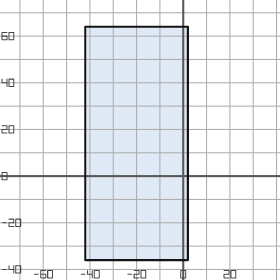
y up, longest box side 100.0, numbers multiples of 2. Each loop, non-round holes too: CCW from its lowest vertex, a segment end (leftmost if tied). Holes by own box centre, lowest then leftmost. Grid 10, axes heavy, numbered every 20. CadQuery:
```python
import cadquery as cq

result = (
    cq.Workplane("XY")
    .moveTo(-42.0, -36.0)
    .lineTo(2.0, -36.0)
    .lineTo(2.0, 64.0)
    .lineTo(-42.0, 64.0)
    .close()
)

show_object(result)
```